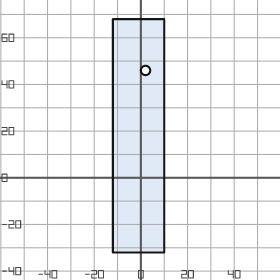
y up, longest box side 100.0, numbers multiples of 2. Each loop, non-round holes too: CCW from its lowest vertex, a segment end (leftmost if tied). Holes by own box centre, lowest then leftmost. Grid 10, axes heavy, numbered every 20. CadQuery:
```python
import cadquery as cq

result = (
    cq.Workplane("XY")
    .moveTo(-12.0, -32.0)
    .lineTo(10.0, -32.0)
    .lineTo(10.0, 68.0)
    .lineTo(-12.0, 68.0)
    .close()
    .moveTo(2.0, 46.0)
    .circle(2.0)
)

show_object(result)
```